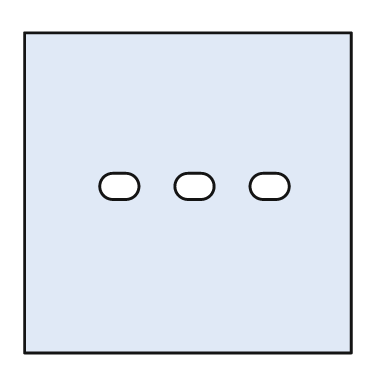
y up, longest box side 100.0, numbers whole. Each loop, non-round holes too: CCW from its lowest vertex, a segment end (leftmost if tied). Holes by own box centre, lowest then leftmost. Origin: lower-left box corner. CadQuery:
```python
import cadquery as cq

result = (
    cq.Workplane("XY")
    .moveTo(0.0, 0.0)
    .lineTo(100.0, 0.0)
    .lineTo(100.0, 98.0)
    .lineTo(0.0, 98.0)
    .close()
    .moveTo(27.0, 47.0)
    .lineTo(31.0, 47.0)
    .threePointArc((35.0, 51.0), (31.0, 55.0))
    .lineTo(27.0, 55.0)
    .threePointArc((23.0, 51.0), (27.0, 47.0))
    .close()
    .moveTo(50.0, 47.0)
    .lineTo(54.0, 47.0)
    .threePointArc((58.0, 51.0), (54.0, 55.0))
    .lineTo(50.0, 55.0)
    .threePointArc((46.0, 51.0), (50.0, 47.0))
    .close()
    .moveTo(73.0, 47.0)
    .lineTo(77.0, 47.0)
    .threePointArc((81.0, 51.0), (77.0, 55.0))
    .lineTo(73.0, 55.0)
    .threePointArc((69.0, 51.0), (73.0, 47.0))
    .close()
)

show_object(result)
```